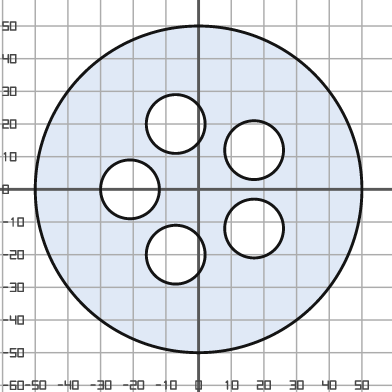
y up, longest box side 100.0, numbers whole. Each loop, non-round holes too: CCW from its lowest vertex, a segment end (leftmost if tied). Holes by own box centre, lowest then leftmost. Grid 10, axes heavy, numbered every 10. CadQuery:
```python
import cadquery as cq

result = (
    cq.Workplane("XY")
    .moveTo(0.0, 0.0)
    .circle(50.0)
    .moveTo(-7.0, -20.0)
    .circle(9.0)
    .moveTo(17.0, -12.0)
    .circle(9.0)
    .moveTo(-21.0, 0.0)
    .circle(9.0)
    .moveTo(17.0, 12.0)
    .circle(9.0)
    .moveTo(-7.0, 20.0)
    .circle(9.0)
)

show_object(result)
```